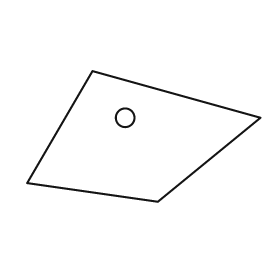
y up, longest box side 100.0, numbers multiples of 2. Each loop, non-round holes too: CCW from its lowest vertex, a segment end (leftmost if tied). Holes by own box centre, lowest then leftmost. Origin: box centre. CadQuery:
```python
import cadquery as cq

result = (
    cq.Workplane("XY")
    .moveTo(6.0, -28.0)
    .lineTo(50.0, 8.0)
    .lineTo(-22.0, 28.0)
    .lineTo(-50.0, -20.0)
    .close()
    .moveTo(-8.0, 8.0)
    .circle(4.0)
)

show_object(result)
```